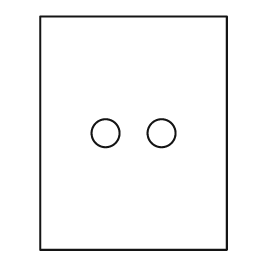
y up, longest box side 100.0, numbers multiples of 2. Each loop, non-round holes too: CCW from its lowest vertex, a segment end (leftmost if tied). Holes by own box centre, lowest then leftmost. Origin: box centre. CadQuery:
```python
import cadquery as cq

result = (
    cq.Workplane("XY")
    .moveTo(-40.0, -50.0)
    .lineTo(40.0, -50.0)
    .lineTo(40.0, 50.0)
    .lineTo(-40.0, 50.0)
    .close()
    .moveTo(-12.0, 0.0)
    .circle(6.0)
    .moveTo(12.0, 0.0)
    .circle(6.0)
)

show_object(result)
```